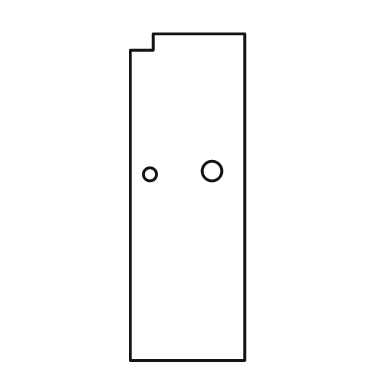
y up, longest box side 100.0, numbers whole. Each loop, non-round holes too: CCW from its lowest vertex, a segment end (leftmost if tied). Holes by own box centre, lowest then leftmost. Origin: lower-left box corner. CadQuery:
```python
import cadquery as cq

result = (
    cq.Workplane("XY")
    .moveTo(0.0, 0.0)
    .lineTo(35.0, 0.0)
    .lineTo(35.0, 100.0)
    .lineTo(7.0, 100.0)
    .lineTo(7.0, 95.0)
    .lineTo(0.0, 95.0)
    .close()
    .moveTo(6.0, 57.0)
    .circle(2.0)
    .moveTo(25.0, 58.0)
    .circle(3.0)
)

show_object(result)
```